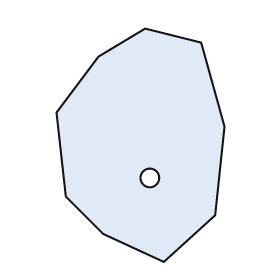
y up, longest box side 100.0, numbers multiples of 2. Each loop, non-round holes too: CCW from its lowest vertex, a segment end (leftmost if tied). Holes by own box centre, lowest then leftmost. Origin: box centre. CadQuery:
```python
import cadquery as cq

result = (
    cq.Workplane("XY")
    .moveTo(10.0, -50.0)
    .lineTo(32.0, -30.0)
    .lineTo(36.0, 8.0)
    .lineTo(26.0, 44.0)
    .lineTo(2.0, 50.0)
    .lineTo(-18.0, 38.0)
    .lineTo(-36.0, 14.0)
    .lineTo(-32.0, -22.0)
    .lineTo(-16.0, -38.0)
    .close()
    .moveTo(4.0, -14.0)
    .circle(4.0)
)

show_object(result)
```